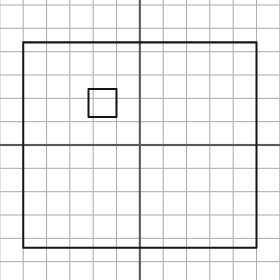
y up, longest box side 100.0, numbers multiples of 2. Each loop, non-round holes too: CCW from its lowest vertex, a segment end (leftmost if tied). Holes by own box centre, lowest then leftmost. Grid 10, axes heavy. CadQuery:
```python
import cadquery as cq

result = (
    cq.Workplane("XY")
    .moveTo(-50.0, -44.0)
    .lineTo(50.0, -44.0)
    .lineTo(50.0, 44.0)
    .lineTo(-50.0, 44.0)
    .close()
    .moveTo(-22.0, 12.0)
    .lineTo(-10.0, 12.0)
    .lineTo(-10.0, 24.0)
    .lineTo(-22.0, 24.0)
    .close()
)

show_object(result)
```